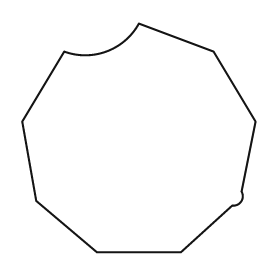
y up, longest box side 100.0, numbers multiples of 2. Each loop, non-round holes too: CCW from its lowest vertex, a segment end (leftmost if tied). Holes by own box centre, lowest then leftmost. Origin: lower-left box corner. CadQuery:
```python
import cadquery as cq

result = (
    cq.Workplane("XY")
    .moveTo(32.0, 0.0)
    .lineTo(68.0, 0.0)
    .lineTo(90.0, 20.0)
    .threePointArc((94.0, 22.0), (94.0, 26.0))
    .lineTo(100.0, 56.0)
    .lineTo(82.0, 86.0)
    .lineTo(50.0, 98.0)
    .threePointArc((36.0, 86.0), (18.0, 86.0))
    .lineTo(0.0, 56.0)
    .lineTo(6.0, 22.0)
    .close()
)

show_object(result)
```